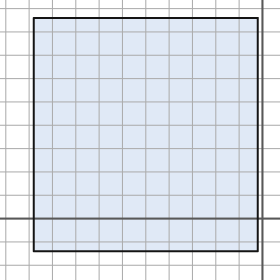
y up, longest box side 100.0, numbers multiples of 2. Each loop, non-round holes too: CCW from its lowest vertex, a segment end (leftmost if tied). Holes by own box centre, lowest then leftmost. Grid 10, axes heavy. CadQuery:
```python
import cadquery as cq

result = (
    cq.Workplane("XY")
    .moveTo(-98.0, -14.0)
    .lineTo(-2.0, -14.0)
    .lineTo(-2.0, 86.0)
    .lineTo(-98.0, 86.0)
    .close()
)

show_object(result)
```